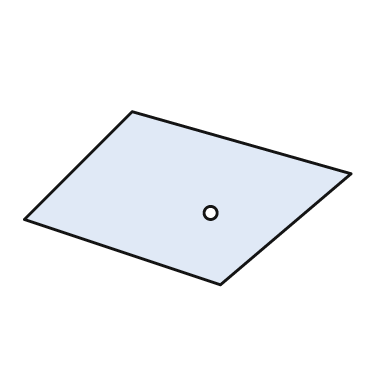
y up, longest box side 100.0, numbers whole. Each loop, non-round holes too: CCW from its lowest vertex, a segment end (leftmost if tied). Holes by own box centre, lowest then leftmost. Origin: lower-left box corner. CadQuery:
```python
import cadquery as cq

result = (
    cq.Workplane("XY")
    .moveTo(60.0, 0.0)
    .lineTo(100.0, 34.0)
    .lineTo(33.0, 53.0)
    .lineTo(0.0, 20.0)
    .close()
    .moveTo(57.0, 22.0)
    .circle(2.0)
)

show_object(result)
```